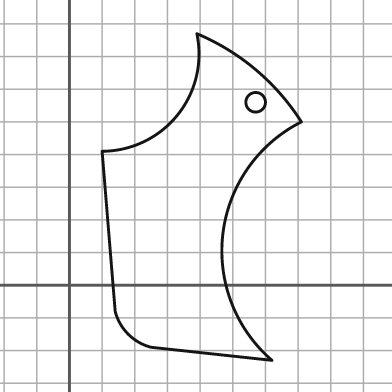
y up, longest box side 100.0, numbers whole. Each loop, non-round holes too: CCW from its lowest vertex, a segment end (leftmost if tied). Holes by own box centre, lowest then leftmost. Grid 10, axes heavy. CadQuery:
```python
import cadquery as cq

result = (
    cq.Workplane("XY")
    .moveTo(62.0, -23.0)
    .threePointArc((47.0, 16.0), (71.0, 50.0))
    .threePointArc((57.0, 66.0), (39.0, 77.0))
    .threePointArc((33.0, 52.0), (10.0, 41.0))
    .lineTo(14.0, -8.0)
    .threePointArc((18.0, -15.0), (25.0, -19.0))
    .close()
    .moveTo(57.0, 56.0)
    .circle(3.0)
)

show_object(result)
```